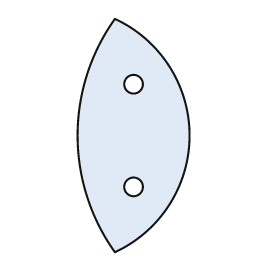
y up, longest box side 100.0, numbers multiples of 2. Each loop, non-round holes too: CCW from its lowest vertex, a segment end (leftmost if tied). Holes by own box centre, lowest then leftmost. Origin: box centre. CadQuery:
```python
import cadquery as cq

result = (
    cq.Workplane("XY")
    .moveTo(-8.0, -50.0)
    .threePointArc((24.0, 0.0), (-8.0, 50.0))
    .threePointArc((-24.0, 0.0), (-8.0, -50.0))
    .close()
    .moveTo(0.0, -22.0)
    .circle(4.0)
    .moveTo(0.0, 22.0)
    .circle(4.0)
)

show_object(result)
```